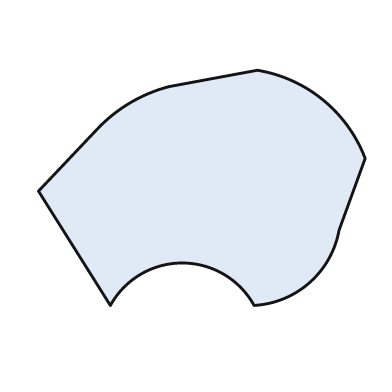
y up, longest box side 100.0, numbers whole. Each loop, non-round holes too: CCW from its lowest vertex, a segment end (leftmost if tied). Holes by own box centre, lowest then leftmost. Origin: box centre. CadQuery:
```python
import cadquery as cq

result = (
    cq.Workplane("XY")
    .moveTo(-28.0, -36.0)
    .threePointArc((-6.0, -23.0), (16.0, -36.0))
    .threePointArc((33.0, -29.0), (42.0, -13.0))
    .lineTo(50.0, 9.0)
    .threePointArc((37.0, 27.0), (17.0, 36.0))
    .lineTo(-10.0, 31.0)
    .threePointArc((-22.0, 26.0), (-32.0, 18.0))
    .lineTo(-50.0, -1.0)
    .close()
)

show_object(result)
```